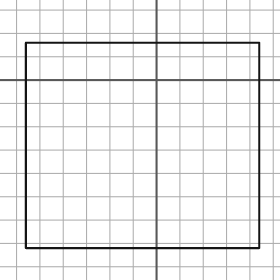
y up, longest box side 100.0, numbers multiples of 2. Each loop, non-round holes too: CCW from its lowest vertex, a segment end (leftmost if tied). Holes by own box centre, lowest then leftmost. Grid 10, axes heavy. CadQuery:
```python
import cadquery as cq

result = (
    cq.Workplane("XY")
    .moveTo(-56.0, -72.0)
    .lineTo(44.0, -72.0)
    .lineTo(44.0, 16.0)
    .lineTo(-56.0, 16.0)
    .close()
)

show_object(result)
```